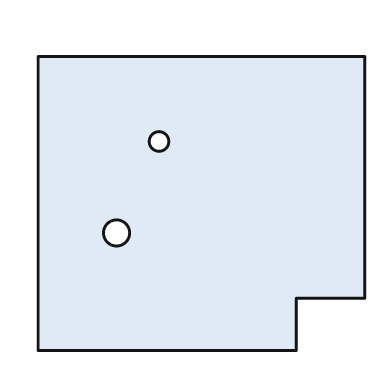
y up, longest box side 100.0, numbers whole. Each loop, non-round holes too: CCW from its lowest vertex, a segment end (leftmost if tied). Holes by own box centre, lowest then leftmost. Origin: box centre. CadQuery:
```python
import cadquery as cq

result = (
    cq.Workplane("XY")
    .moveTo(-50.0, -45.0)
    .lineTo(29.0, -45.0)
    .lineTo(29.0, -29.0)
    .lineTo(50.0, -29.0)
    .lineTo(50.0, 45.0)
    .lineTo(-50.0, 45.0)
    .close()
    .moveTo(-26.0, -9.0)
    .circle(4.0)
    .moveTo(-13.0, 19.0)
    .circle(3.0)
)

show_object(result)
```